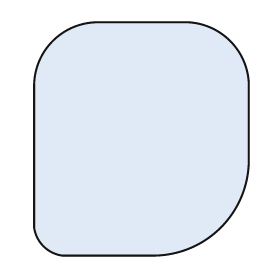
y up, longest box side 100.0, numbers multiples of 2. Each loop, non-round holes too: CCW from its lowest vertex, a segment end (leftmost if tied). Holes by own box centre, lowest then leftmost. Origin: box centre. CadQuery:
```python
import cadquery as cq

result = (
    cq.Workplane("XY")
    .moveTo(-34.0, -50.0)
    .lineTo(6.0, -50.0)
    .threePointArc((34.0, -38.0), (46.0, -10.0))
    .lineTo(46.0, 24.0)
    .threePointArc((38.0, 42.0), (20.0, 50.0))
    .lineTo(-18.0, 50.0)
    .threePointArc((-38.0, 42.0), (-46.0, 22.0))
    .lineTo(-46.0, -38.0)
    .threePointArc((-42.0, -46.0), (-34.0, -50.0))
    .close()
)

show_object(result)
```